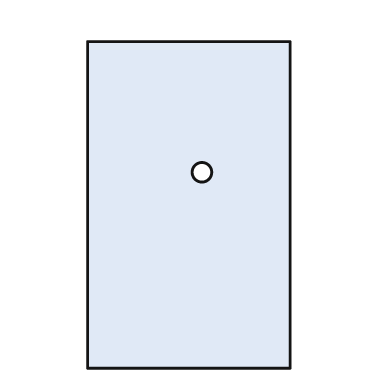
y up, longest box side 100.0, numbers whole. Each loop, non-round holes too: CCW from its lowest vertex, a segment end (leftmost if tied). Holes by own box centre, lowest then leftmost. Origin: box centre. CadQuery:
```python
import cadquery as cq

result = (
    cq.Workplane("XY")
    .moveTo(-31.0, -50.0)
    .lineTo(31.0, -50.0)
    .lineTo(31.0, 50.0)
    .lineTo(-31.0, 50.0)
    .close()
    .moveTo(4.0, 10.0)
    .circle(3.0)
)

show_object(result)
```